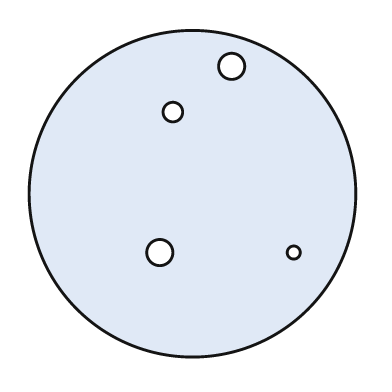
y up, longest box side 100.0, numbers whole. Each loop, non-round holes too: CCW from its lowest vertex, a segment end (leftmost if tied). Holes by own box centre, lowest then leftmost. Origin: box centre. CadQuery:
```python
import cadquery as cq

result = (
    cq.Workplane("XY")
    .moveTo(0.0, 0.0)
    .circle(50.0)
    .moveTo(-10.0, -18.0)
    .circle(4.0)
    .moveTo(31.0, -18.0)
    .circle(2.0)
    .moveTo(-6.0, 25.0)
    .circle(3.0)
    .moveTo(12.0, 39.0)
    .circle(4.0)
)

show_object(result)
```